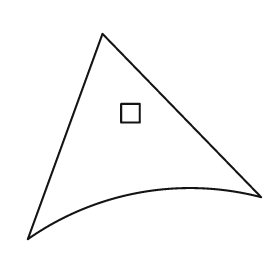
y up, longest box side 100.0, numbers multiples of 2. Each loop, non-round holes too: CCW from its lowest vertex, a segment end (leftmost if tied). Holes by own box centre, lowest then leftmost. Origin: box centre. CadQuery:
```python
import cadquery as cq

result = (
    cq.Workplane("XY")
    .moveTo(-50.0, -44.0)
    .threePointArc((-2.0, -24.0), (50.0, -26.0))
    .lineTo(-18.0, 44.0)
    .close()
    .moveTo(-10.0, 6.0)
    .lineTo(-2.0, 6.0)
    .lineTo(-2.0, 14.0)
    .lineTo(-10.0, 14.0)
    .close()
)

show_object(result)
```